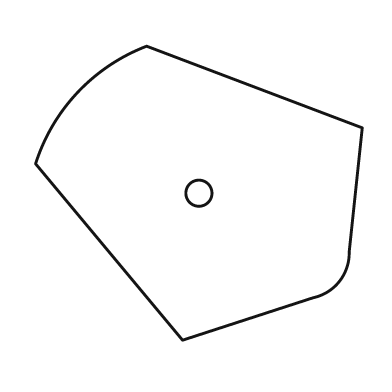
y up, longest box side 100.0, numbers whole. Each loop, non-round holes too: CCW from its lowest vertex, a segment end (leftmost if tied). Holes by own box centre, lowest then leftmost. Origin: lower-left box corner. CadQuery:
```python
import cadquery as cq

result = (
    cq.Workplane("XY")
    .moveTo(45.0, 0.0)
    .lineTo(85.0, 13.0)
    .threePointArc((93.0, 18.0), (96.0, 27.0))
    .lineTo(100.0, 65.0)
    .lineTo(34.0, 90.0)
    .threePointArc((13.0, 76.0), (0.0, 54.0))
    .close()
    .moveTo(50.0, 45.0)
    .circle(4.0)
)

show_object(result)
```